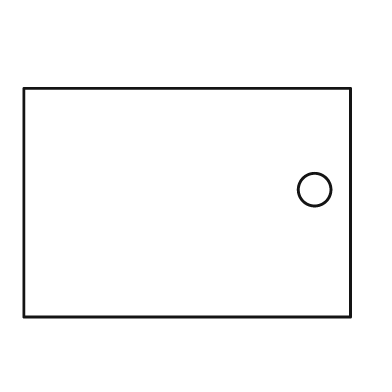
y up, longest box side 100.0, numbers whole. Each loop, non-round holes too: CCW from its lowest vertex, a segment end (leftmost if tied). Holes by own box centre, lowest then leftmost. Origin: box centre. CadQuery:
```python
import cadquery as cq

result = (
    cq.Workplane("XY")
    .moveTo(-50.0, -35.0)
    .lineTo(50.0, -35.0)
    .lineTo(50.0, 35.0)
    .lineTo(-50.0, 35.0)
    .close()
    .moveTo(39.0, 4.0)
    .circle(5.0)
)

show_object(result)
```